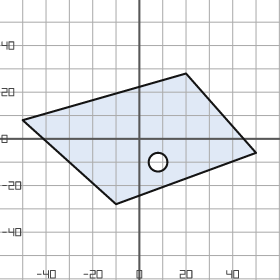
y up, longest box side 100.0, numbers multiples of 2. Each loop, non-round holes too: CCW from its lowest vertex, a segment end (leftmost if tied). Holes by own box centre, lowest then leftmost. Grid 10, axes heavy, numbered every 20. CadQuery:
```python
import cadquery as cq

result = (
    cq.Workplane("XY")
    .moveTo(-10.0, -28.0)
    .lineTo(50.0, -6.0)
    .lineTo(20.0, 28.0)
    .lineTo(-50.0, 8.0)
    .close()
    .moveTo(8.0, -10.0)
    .circle(4.0)
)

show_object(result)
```